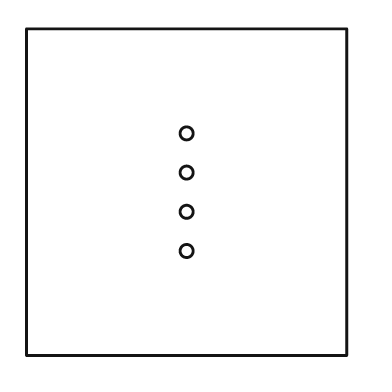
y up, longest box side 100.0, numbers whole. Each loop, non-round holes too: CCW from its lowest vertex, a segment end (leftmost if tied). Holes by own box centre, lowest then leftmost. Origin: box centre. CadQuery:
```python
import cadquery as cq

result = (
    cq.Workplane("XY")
    .moveTo(-49.0, -50.0)
    .lineTo(49.0, -50.0)
    .lineTo(49.0, 50.0)
    .lineTo(-49.0, 50.0)
    .close()
    .moveTo(0.0, -18.0)
    .circle(2.0)
    .moveTo(0.0, -6.0)
    .circle(2.0)
    .moveTo(0.0, 6.0)
    .circle(2.0)
    .moveTo(0.0, 18.0)
    .circle(2.0)
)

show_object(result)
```